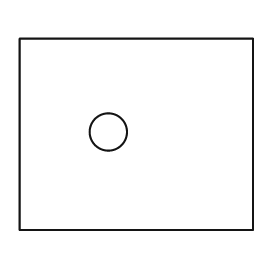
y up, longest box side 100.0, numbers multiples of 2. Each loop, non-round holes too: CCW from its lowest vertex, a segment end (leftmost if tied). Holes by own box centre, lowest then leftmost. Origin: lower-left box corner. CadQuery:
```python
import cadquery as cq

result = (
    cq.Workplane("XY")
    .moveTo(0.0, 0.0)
    .lineTo(100.0, 0.0)
    .lineTo(100.0, 82.0)
    .lineTo(0.0, 82.0)
    .close()
    .moveTo(38.0, 42.0)
    .circle(8.0)
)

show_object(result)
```